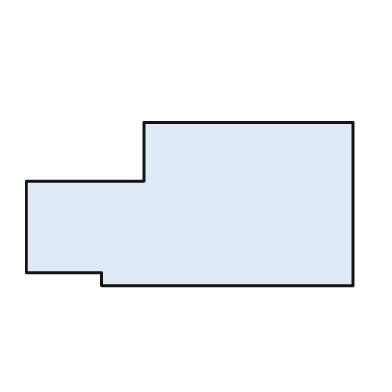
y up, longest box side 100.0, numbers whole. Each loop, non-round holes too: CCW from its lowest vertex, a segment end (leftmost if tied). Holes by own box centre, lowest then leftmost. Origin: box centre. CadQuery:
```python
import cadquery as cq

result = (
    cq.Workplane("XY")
    .moveTo(-27.0, -25.0)
    .lineTo(50.0, -25.0)
    .lineTo(50.0, 25.0)
    .lineTo(-14.0, 25.0)
    .lineTo(-14.0, 7.0)
    .lineTo(-50.0, 7.0)
    .lineTo(-50.0, -21.0)
    .lineTo(-27.0, -21.0)
    .close()
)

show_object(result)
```